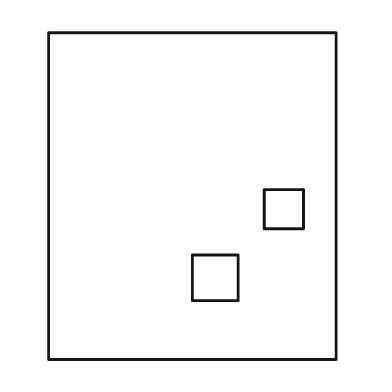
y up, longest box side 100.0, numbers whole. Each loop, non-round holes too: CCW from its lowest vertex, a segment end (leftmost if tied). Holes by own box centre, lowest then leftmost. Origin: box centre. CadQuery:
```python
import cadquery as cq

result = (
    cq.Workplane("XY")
    .moveTo(-44.0, -50.0)
    .lineTo(44.0, -50.0)
    .lineTo(44.0, 50.0)
    .lineTo(-44.0, 50.0)
    .close()
    .moveTo(0.0, -32.0)
    .lineTo(14.0, -32.0)
    .lineTo(14.0, -18.0)
    .lineTo(0.0, -18.0)
    .close()
    .moveTo(22.0, -10.0)
    .lineTo(34.0, -10.0)
    .lineTo(34.0, 2.0)
    .lineTo(22.0, 2.0)
    .close()
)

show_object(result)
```